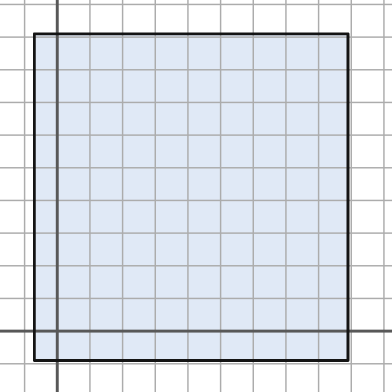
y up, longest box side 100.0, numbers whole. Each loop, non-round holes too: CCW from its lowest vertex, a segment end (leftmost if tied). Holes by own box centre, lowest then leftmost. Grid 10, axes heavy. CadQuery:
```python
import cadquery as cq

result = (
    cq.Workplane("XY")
    .moveTo(-7.0, -9.0)
    .lineTo(89.0, -9.0)
    .lineTo(89.0, 91.0)
    .lineTo(-7.0, 91.0)
    .close()
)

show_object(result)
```